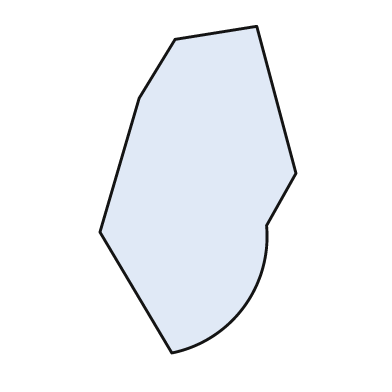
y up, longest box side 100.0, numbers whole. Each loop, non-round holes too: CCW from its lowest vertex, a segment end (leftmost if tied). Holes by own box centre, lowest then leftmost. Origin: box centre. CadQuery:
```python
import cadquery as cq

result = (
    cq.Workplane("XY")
    .moveTo(-8.0, -50.0)
    .threePointArc((14.0, -36.0), (21.0, -11.0))
    .lineTo(30.0, 5.0)
    .lineTo(18.0, 50.0)
    .lineTo(-7.0, 46.0)
    .lineTo(-18.0, 28.0)
    .lineTo(-30.0, -13.0)
    .close()
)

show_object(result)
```